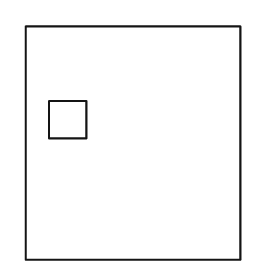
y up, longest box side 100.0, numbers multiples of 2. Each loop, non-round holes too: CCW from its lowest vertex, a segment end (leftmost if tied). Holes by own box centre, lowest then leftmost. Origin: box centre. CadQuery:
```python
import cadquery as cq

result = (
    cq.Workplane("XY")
    .moveTo(-46.0, -50.0)
    .lineTo(46.0, -50.0)
    .lineTo(46.0, 50.0)
    .lineTo(-46.0, 50.0)
    .close()
    .moveTo(-36.0, 2.0)
    .lineTo(-20.0, 2.0)
    .lineTo(-20.0, 18.0)
    .lineTo(-36.0, 18.0)
    .close()
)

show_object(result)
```